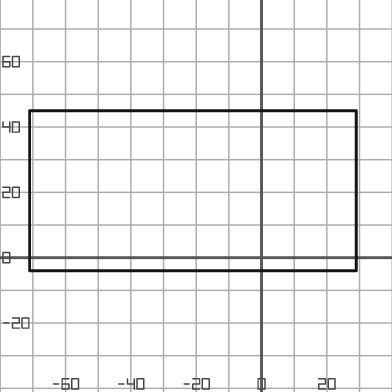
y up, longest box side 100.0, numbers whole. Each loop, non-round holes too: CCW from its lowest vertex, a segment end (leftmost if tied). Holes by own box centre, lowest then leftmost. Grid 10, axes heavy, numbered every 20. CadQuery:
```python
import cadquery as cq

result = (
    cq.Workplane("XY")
    .moveTo(-71.0, -4.0)
    .lineTo(29.0, -4.0)
    .lineTo(29.0, 45.0)
    .lineTo(-71.0, 45.0)
    .close()
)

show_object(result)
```